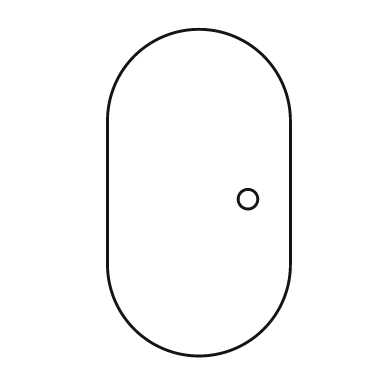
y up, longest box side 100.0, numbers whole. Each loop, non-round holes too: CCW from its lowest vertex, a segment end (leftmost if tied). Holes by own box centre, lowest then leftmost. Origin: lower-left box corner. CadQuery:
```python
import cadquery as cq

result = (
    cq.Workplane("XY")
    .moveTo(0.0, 28.0)
    .threePointArc((28.0, 0.0), (56.0, 28.0))
    .lineTo(56.0, 72.0)
    .threePointArc((28.0, 100.0), (0.0, 72.0))
    .close()
    .moveTo(43.0, 48.0)
    .circle(3.0)
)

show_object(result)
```